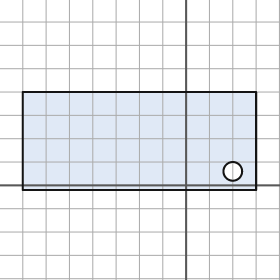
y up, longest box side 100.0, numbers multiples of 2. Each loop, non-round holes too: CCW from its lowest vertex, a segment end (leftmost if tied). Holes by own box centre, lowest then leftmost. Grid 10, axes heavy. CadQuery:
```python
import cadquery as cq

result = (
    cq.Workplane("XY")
    .moveTo(-70.0, -2.0)
    .lineTo(30.0, -2.0)
    .lineTo(30.0, 40.0)
    .lineTo(-70.0, 40.0)
    .close()
    .moveTo(20.0, 6.0)
    .circle(4.0)
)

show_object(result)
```